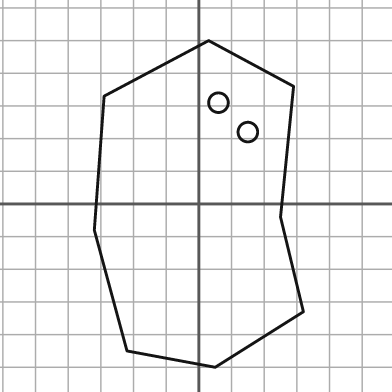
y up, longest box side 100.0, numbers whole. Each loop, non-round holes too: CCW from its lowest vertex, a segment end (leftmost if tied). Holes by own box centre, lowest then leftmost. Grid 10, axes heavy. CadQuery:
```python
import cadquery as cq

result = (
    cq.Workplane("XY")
    .moveTo(5.0, -50.0)
    .lineTo(32.0, -33.0)
    .lineTo(25.0, -4.0)
    .lineTo(29.0, 36.0)
    .lineTo(3.0, 50.0)
    .lineTo(-29.0, 33.0)
    .lineTo(-32.0, -8.0)
    .lineTo(-22.0, -45.0)
    .close()
    .moveTo(15.0, 22.0)
    .circle(3.0)
    .moveTo(6.0, 31.0)
    .circle(3.0)
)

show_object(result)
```